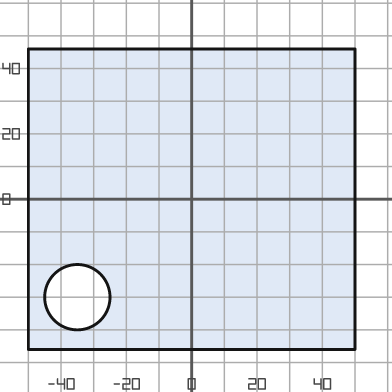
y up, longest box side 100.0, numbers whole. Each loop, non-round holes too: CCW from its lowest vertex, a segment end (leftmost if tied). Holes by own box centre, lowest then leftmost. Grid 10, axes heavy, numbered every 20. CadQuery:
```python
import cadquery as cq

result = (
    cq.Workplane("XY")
    .moveTo(-50.0, -46.0)
    .lineTo(50.0, -46.0)
    .lineTo(50.0, 46.0)
    .lineTo(-50.0, 46.0)
    .close()
    .moveTo(-35.0, -30.0)
    .circle(10.0)
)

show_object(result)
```